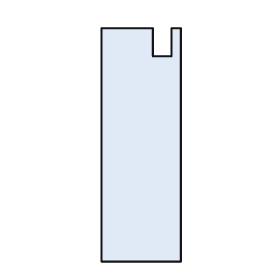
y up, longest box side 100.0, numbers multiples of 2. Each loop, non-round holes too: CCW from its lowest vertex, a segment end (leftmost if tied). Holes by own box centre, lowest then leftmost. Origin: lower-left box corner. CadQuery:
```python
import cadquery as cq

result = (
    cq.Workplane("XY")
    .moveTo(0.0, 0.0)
    .lineTo(34.0, 0.0)
    .lineTo(34.0, 100.0)
    .lineTo(30.0, 100.0)
    .lineTo(30.0, 88.0)
    .lineTo(22.0, 88.0)
    .lineTo(22.0, 100.0)
    .lineTo(0.0, 100.0)
    .close()
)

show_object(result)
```